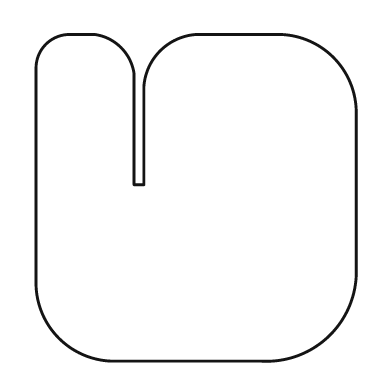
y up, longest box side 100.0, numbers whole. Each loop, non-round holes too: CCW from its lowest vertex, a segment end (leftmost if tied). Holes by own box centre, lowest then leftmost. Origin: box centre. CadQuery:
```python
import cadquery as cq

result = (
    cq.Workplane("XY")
    .moveTo(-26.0, -50.0)
    .lineTo(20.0, -50.0)
    .threePointArc((41.0, -42.0), (49.0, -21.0))
    .lineTo(49.0, 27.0)
    .threePointArc((42.0, 43.0), (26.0, 50.0))
    .lineTo(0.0, 50.0)
    .threePointArc((-11.0, 45.0), (-16.0, 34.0))
    .lineTo(-16.0, 4.0)
    .lineTo(-19.0, 4.0)
    .lineTo(-19.0, 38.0)
    .threePointArc((-23.0, 46.0), (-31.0, 50.0))
    .lineTo(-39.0, 50.0)
    .threePointArc((-46.0, 47.0), (-49.0, 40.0))
    .lineTo(-49.0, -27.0)
    .threePointArc((-42.0, -43.0), (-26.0, -50.0))
    .close()
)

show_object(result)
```